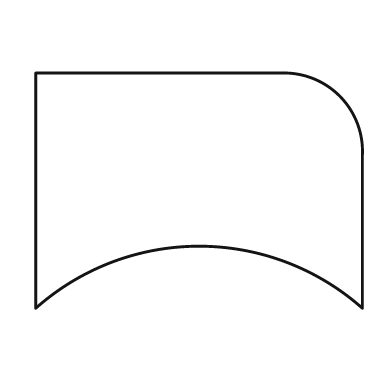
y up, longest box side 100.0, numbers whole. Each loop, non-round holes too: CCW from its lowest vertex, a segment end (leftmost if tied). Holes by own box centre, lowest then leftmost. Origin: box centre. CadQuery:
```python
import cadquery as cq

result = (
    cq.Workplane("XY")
    .moveTo(-50.0, -36.0)
    .threePointArc((0.0, -17.0), (50.0, -36.0))
    .lineTo(50.0, 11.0)
    .threePointArc((43.0, 29.0), (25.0, 36.0))
    .lineTo(-50.0, 36.0)
    .close()
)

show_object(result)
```